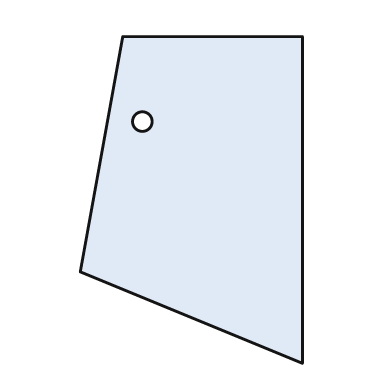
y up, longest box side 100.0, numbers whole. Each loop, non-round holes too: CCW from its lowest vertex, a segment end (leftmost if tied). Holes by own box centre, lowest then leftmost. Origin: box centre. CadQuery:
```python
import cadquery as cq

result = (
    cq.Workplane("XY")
    .moveTo(34.0, -50.0)
    .lineTo(34.0, 50.0)
    .lineTo(-21.0, 50.0)
    .lineTo(-34.0, -22.0)
    .close()
    .moveTo(-15.0, 24.0)
    .circle(3.0)
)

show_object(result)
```